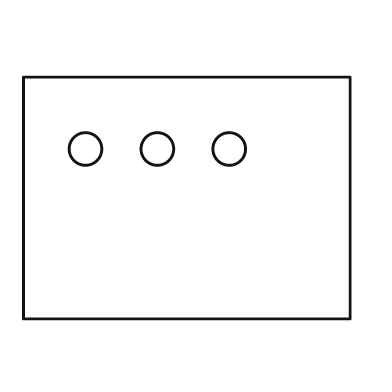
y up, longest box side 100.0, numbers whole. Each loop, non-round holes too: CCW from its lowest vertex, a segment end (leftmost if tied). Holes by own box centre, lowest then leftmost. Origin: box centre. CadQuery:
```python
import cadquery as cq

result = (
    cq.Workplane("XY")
    .moveTo(-50.0, -37.0)
    .lineTo(50.0, -37.0)
    .lineTo(50.0, 37.0)
    .lineTo(-50.0, 37.0)
    .close()
    .moveTo(-31.0, 15.0)
    .circle(5.0)
    .moveTo(-9.0, 15.0)
    .circle(5.0)
    .moveTo(13.0, 15.0)
    .circle(5.0)
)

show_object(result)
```